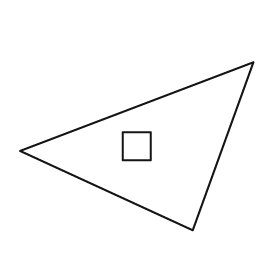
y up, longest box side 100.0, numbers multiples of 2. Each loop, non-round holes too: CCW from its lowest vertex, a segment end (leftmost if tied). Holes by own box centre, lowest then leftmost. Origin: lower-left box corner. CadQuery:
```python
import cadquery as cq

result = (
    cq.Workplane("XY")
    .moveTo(74.0, 0.0)
    .lineTo(100.0, 72.0)
    .lineTo(0.0, 34.0)
    .close()
    .moveTo(44.0, 30.0)
    .lineTo(56.0, 30.0)
    .lineTo(56.0, 42.0)
    .lineTo(44.0, 42.0)
    .close()
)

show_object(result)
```